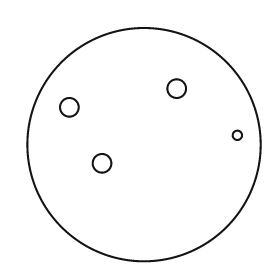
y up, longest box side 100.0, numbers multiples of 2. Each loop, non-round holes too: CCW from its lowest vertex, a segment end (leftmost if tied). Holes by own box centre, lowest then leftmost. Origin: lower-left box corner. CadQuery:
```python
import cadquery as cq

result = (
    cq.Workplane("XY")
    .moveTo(50.0, 50.0)
    .circle(50.0)
    .moveTo(32.0, 42.0)
    .circle(4.0)
    .moveTo(90.0, 54.0)
    .circle(2.0)
    .moveTo(18.0, 66.0)
    .circle(4.0)
    .moveTo(64.0, 74.0)
    .circle(4.0)
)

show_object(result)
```